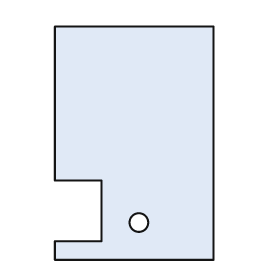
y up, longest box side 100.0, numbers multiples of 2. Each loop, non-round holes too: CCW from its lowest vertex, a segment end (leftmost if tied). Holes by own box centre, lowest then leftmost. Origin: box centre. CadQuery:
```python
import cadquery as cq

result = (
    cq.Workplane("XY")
    .moveTo(-34.0, -50.0)
    .lineTo(34.0, -50.0)
    .lineTo(34.0, 50.0)
    .lineTo(-34.0, 50.0)
    .lineTo(-34.0, -16.0)
    .lineTo(-14.0, -16.0)
    .lineTo(-14.0, -42.0)
    .lineTo(-34.0, -42.0)
    .close()
    .moveTo(2.0, -34.0)
    .circle(4.0)
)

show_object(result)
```